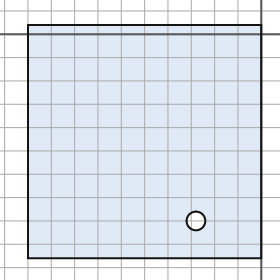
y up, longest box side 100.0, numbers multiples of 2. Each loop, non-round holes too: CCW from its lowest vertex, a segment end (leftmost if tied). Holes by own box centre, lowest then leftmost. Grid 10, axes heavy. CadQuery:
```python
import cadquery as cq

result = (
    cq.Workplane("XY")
    .moveTo(-100.0, -96.0)
    .lineTo(0.0, -96.0)
    .lineTo(0.0, 4.0)
    .lineTo(-100.0, 4.0)
    .close()
    .moveTo(-28.0, -80.0)
    .circle(4.0)
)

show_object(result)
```